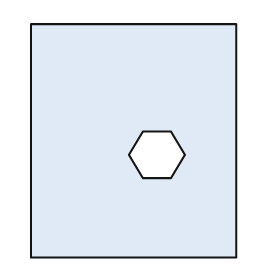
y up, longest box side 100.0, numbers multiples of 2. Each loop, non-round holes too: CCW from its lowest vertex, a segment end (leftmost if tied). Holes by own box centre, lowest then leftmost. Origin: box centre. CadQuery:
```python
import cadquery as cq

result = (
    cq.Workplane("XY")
    .moveTo(-44.0, -50.0)
    .lineTo(44.0, -50.0)
    .lineTo(44.0, 50.0)
    .lineTo(-44.0, 50.0)
    .close()
    .moveTo(4.0, -16.0)
    .lineTo(16.0, -16.0)
    .lineTo(22.0, -6.0)
    .lineTo(16.0, 4.0)
    .lineTo(4.0, 4.0)
    .lineTo(-2.0, -6.0)
    .close()
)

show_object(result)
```